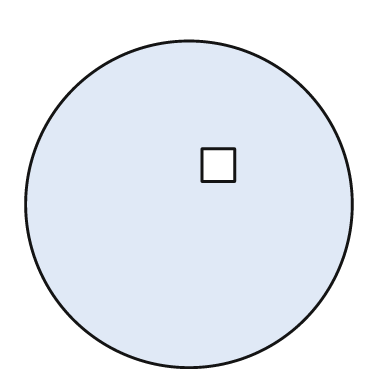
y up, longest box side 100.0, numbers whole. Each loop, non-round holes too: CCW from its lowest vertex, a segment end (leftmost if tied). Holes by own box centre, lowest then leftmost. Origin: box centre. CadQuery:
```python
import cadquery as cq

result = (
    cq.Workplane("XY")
    .moveTo(0.0, 0.0)
    .circle(50.0)
    .moveTo(4.0, 7.0)
    .lineTo(14.0, 7.0)
    .lineTo(14.0, 17.0)
    .lineTo(4.0, 17.0)
    .close()
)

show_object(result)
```